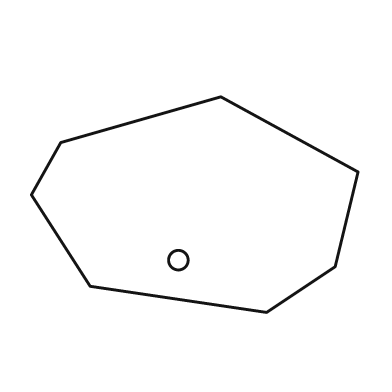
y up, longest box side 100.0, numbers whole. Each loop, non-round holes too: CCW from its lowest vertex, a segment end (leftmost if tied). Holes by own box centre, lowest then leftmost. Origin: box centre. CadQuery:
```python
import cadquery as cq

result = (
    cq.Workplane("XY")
    .moveTo(22.0, -33.0)
    .lineTo(43.0, -19.0)
    .lineTo(50.0, 10.0)
    .lineTo(8.0, 33.0)
    .lineTo(-41.0, 19.0)
    .lineTo(-50.0, 3.0)
    .lineTo(-32.0, -25.0)
    .close()
    .moveTo(-5.0, -17.0)
    .circle(3.0)
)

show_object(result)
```